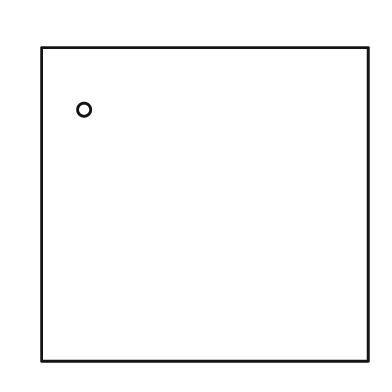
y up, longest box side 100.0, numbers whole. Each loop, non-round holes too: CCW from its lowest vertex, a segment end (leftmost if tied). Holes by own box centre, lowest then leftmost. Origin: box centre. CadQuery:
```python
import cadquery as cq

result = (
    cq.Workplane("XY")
    .moveTo(-50.0, -48.0)
    .lineTo(50.0, -48.0)
    .lineTo(50.0, 48.0)
    .lineTo(-50.0, 48.0)
    .close()
    .moveTo(-37.0, 29.0)
    .circle(2.0)
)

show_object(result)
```